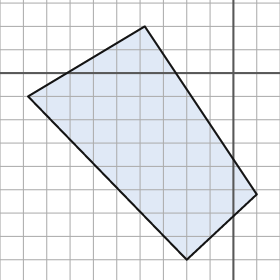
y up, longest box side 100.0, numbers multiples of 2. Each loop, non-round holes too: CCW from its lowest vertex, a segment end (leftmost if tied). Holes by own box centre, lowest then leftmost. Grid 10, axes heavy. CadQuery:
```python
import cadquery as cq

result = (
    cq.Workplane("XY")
    .moveTo(-20.0, -80.0)
    .lineTo(10.0, -52.0)
    .lineTo(-38.0, 20.0)
    .lineTo(-88.0, -10.0)
    .close()
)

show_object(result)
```